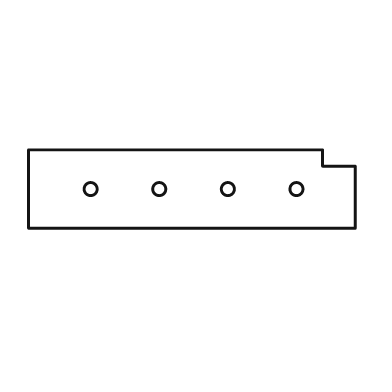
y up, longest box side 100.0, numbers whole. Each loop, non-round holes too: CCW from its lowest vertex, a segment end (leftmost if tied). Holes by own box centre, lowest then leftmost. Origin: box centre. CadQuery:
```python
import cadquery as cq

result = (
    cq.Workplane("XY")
    .moveTo(-50.0, -12.0)
    .lineTo(50.0, -12.0)
    .lineTo(50.0, 7.0)
    .lineTo(40.0, 7.0)
    .lineTo(40.0, 12.0)
    .lineTo(-50.0, 12.0)
    .close()
    .moveTo(-31.0, 0.0)
    .circle(2.0)
    .moveTo(-10.0, 0.0)
    .circle(2.0)
    .moveTo(11.0, 0.0)
    .circle(2.0)
    .moveTo(32.0, 0.0)
    .circle(2.0)
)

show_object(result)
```